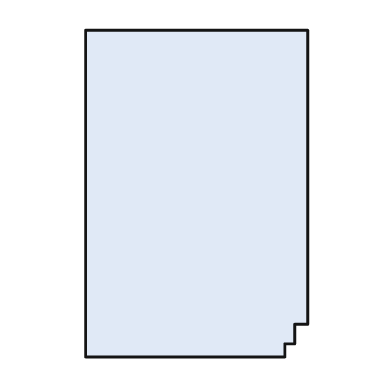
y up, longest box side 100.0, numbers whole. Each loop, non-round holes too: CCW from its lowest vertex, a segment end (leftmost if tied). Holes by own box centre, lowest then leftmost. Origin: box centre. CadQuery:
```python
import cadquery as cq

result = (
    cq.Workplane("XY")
    .moveTo(-34.0, -50.0)
    .lineTo(27.0, -50.0)
    .lineTo(27.0, -46.0)
    .lineTo(30.0, -46.0)
    .lineTo(30.0, -40.0)
    .lineTo(34.0, -40.0)
    .lineTo(34.0, 50.0)
    .lineTo(-34.0, 50.0)
    .close()
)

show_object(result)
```